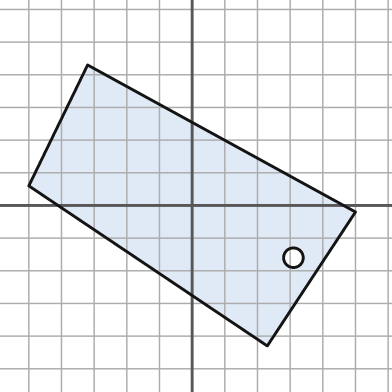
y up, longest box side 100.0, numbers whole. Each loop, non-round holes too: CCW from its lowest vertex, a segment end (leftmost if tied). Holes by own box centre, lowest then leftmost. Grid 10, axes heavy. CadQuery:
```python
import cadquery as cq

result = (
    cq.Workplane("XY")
    .moveTo(23.0, -43.0)
    .lineTo(50.0, -2.0)
    .lineTo(-32.0, 43.0)
    .lineTo(-50.0, 6.0)
    .close()
    .moveTo(31.0, -16.0)
    .circle(3.0)
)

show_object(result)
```